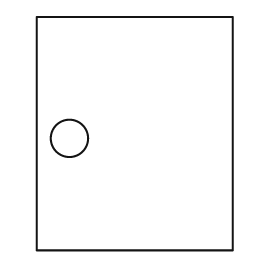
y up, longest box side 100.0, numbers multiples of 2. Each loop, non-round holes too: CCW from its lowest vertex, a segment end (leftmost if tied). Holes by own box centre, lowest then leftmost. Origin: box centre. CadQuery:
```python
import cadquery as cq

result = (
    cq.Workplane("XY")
    .moveTo(-42.0, -50.0)
    .lineTo(42.0, -50.0)
    .lineTo(42.0, 50.0)
    .lineTo(-42.0, 50.0)
    .close()
    .moveTo(-28.0, -2.0)
    .circle(8.0)
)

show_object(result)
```